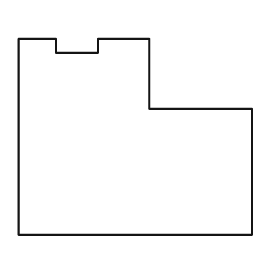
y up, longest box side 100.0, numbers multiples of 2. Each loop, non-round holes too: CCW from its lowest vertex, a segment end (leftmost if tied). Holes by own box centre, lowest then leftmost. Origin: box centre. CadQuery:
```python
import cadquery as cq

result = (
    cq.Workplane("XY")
    .moveTo(-50.0, -42.0)
    .lineTo(50.0, -42.0)
    .lineTo(50.0, 12.0)
    .lineTo(6.0, 12.0)
    .lineTo(6.0, 42.0)
    .lineTo(-16.0, 42.0)
    .lineTo(-16.0, 36.0)
    .lineTo(-34.0, 36.0)
    .lineTo(-34.0, 42.0)
    .lineTo(-50.0, 42.0)
    .close()
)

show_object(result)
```